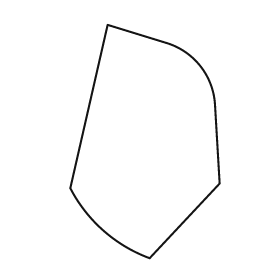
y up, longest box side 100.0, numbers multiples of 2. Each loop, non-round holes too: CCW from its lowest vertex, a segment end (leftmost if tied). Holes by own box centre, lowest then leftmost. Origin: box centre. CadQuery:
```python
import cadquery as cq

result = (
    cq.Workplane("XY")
    .moveTo(2.0, -50.0)
    .lineTo(32.0, -18.0)
    .lineTo(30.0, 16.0)
    .threePointArc((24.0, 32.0), (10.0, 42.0))
    .lineTo(-16.0, 50.0)
    .lineTo(-32.0, -20.0)
    .threePointArc((-18.0, -38.0), (2.0, -50.0))
    .close()
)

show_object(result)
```